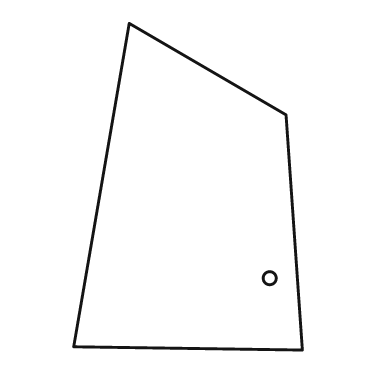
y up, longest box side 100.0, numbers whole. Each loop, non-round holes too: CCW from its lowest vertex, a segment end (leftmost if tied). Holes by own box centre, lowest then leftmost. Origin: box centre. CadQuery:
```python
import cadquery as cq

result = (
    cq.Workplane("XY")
    .moveTo(35.0, -50.0)
    .lineTo(30.0, 22.0)
    .lineTo(-18.0, 50.0)
    .lineTo(-35.0, -49.0)
    .close()
    .moveTo(25.0, -28.0)
    .circle(2.0)
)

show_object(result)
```